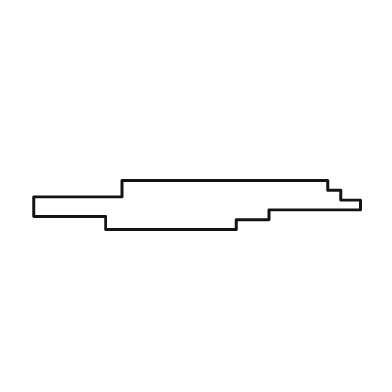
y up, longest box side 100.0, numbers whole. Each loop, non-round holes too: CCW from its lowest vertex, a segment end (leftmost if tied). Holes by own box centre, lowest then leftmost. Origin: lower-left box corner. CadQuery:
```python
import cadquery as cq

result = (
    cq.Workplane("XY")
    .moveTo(22.0, 0.0)
    .lineTo(62.0, 0.0)
    .lineTo(62.0, 3.0)
    .lineTo(72.0, 3.0)
    .lineTo(72.0, 6.0)
    .lineTo(100.0, 6.0)
    .lineTo(100.0, 9.0)
    .lineTo(94.0, 9.0)
    .lineTo(94.0, 12.0)
    .lineTo(90.0, 12.0)
    .lineTo(90.0, 15.0)
    .lineTo(27.0, 15.0)
    .lineTo(27.0, 10.0)
    .lineTo(0.0, 10.0)
    .lineTo(0.0, 4.0)
    .lineTo(22.0, 4.0)
    .close()
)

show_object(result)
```